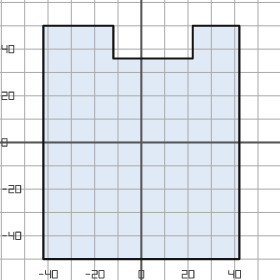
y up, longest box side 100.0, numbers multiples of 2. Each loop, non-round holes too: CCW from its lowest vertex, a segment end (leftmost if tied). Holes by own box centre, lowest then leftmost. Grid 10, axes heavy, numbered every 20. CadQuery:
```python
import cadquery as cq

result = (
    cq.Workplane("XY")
    .moveTo(-42.0, -50.0)
    .lineTo(42.0, -50.0)
    .lineTo(42.0, 50.0)
    .lineTo(22.0, 50.0)
    .lineTo(22.0, 36.0)
    .lineTo(-12.0, 36.0)
    .lineTo(-12.0, 50.0)
    .lineTo(-42.0, 50.0)
    .close()
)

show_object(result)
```